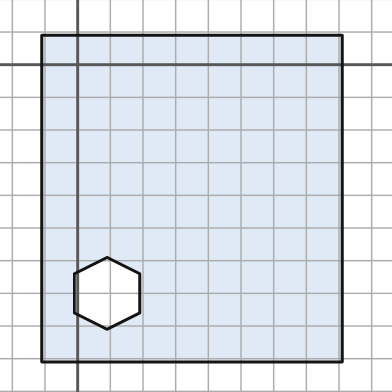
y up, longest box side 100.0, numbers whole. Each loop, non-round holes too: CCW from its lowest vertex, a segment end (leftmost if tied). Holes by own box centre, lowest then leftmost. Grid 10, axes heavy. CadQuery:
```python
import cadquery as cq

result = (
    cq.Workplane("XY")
    .moveTo(-11.0, -91.0)
    .lineTo(81.0, -91.0)
    .lineTo(81.0, 9.0)
    .lineTo(-11.0, 9.0)
    .close()
    .moveTo(9.0, -81.0)
    .lineTo(19.0, -76.0)
    .lineTo(19.0, -64.0)
    .lineTo(9.0, -59.0)
    .lineTo(-1.0, -64.0)
    .lineTo(-1.0, -76.0)
    .close()
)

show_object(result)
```